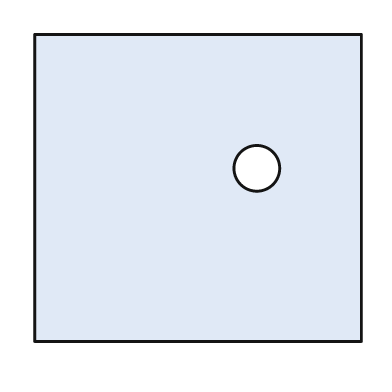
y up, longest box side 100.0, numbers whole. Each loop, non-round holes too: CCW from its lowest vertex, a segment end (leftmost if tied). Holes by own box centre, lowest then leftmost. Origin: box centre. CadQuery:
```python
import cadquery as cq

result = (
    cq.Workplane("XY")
    .moveTo(-50.0, -47.0)
    .lineTo(50.0, -47.0)
    .lineTo(50.0, 47.0)
    .lineTo(-50.0, 47.0)
    .close()
    .moveTo(18.0, 6.0)
    .circle(7.0)
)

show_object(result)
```